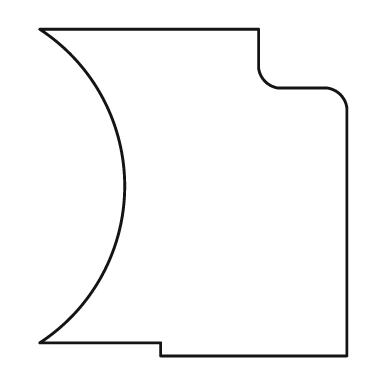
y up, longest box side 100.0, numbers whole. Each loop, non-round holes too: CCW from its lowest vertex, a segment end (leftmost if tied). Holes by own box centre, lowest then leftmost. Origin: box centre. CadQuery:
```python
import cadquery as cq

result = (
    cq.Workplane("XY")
    .moveTo(-10.0, -50.0)
    .lineTo(47.0, -50.0)
    .lineTo(47.0, 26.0)
    .threePointArc((45.0, 30.0), (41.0, 32.0))
    .lineTo(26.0, 32.0)
    .threePointArc((22.0, 34.0), (20.0, 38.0))
    .lineTo(20.0, 50.0)
    .lineTo(-47.0, 50.0)
    .threePointArc((-21.0, 2.0), (-47.0, -46.0))
    .lineTo(-10.0, -46.0)
    .close()
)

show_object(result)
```